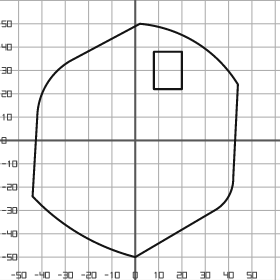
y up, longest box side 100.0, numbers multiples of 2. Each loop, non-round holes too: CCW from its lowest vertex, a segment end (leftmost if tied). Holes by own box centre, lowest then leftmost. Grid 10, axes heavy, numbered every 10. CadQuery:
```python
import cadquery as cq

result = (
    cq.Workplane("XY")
    .moveTo(0.0, -50.0)
    .lineTo(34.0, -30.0)
    .threePointArc((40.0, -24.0), (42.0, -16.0))
    .lineTo(44.0, 24.0)
    .threePointArc((26.0, 42.0), (2.0, 50.0))
    .lineTo(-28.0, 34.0)
    .threePointArc((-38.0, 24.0), (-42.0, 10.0))
    .lineTo(-44.0, -24.0)
    .threePointArc((-24.0, -40.0), (0.0, -50.0))
    .close()
    .moveTo(8.0, 22.0)
    .lineTo(20.0, 22.0)
    .lineTo(20.0, 38.0)
    .lineTo(8.0, 38.0)
    .close()
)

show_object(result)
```